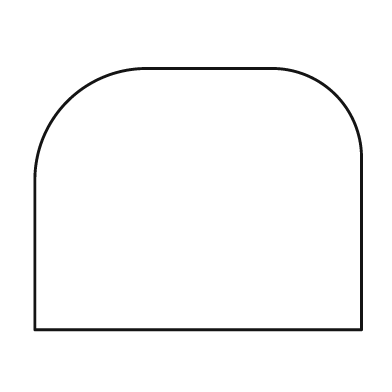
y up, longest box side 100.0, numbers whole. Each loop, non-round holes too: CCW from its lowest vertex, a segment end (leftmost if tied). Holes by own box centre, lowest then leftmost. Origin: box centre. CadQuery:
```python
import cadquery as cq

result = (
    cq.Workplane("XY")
    .moveTo(-50.0, -40.0)
    .lineTo(50.0, -40.0)
    .lineTo(50.0, 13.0)
    .threePointArc((42.0, 32.0), (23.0, 40.0))
    .lineTo(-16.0, 40.0)
    .threePointArc((-40.0, 30.0), (-50.0, 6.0))
    .close()
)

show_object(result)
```